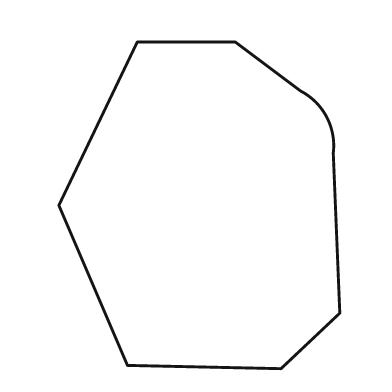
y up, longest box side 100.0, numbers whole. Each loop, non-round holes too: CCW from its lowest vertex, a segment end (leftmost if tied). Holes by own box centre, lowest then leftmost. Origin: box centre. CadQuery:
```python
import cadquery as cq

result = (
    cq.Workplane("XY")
    .moveTo(25.0, -50.0)
    .lineTo(43.0, -33.0)
    .lineTo(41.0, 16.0)
    .threePointArc((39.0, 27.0), (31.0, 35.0))
    .lineTo(11.0, 50.0)
    .lineTo(-19.0, 50.0)
    .lineTo(-43.0, 0.0)
    .lineTo(-22.0, -49.0)
    .close()
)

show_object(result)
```